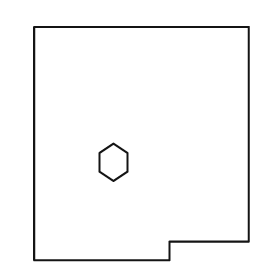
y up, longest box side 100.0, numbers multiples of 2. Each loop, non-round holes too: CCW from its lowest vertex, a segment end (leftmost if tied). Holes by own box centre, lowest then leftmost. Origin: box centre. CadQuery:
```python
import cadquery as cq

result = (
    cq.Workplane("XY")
    .moveTo(-46.0, -50.0)
    .lineTo(12.0, -50.0)
    .lineTo(12.0, -42.0)
    .lineTo(46.0, -42.0)
    .lineTo(46.0, 50.0)
    .lineTo(-46.0, 50.0)
    .close()
    .moveTo(-12.0, -16.0)
    .lineTo(-6.0, -12.0)
    .lineTo(-6.0, -4.0)
    .lineTo(-12.0, 0.0)
    .lineTo(-18.0, -4.0)
    .lineTo(-18.0, -12.0)
    .close()
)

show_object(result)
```